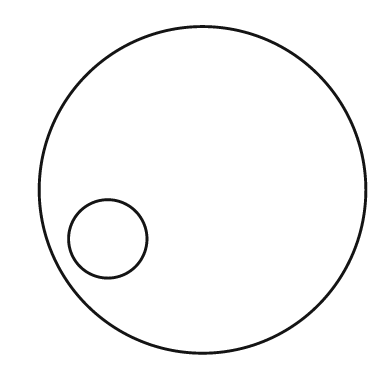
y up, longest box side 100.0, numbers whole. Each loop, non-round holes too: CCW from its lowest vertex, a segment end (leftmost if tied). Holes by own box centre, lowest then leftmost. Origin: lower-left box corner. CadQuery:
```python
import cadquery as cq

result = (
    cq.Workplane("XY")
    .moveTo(50.0, 50.0)
    .circle(50.0)
    .moveTo(21.0, 35.0)
    .circle(12.0)
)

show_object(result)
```